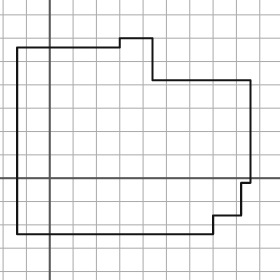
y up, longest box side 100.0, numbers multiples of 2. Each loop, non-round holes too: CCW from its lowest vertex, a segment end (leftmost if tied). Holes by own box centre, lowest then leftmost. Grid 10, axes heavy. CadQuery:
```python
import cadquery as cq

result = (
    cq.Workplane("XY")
    .moveTo(-14.0, -24.0)
    .lineTo(70.0, -24.0)
    .lineTo(70.0, -16.0)
    .lineTo(82.0, -16.0)
    .lineTo(82.0, -2.0)
    .lineTo(86.0, -2.0)
    .lineTo(86.0, 42.0)
    .lineTo(44.0, 42.0)
    .lineTo(44.0, 60.0)
    .lineTo(30.0, 60.0)
    .lineTo(30.0, 56.0)
    .lineTo(-14.0, 56.0)
    .close()
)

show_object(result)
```